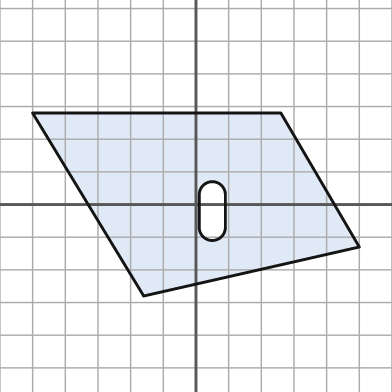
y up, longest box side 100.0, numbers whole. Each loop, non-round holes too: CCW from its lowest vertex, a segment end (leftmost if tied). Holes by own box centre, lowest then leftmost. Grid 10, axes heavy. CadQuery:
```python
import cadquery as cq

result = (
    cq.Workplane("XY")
    .moveTo(-16.0, -28.0)
    .lineTo(50.0, -13.0)
    .lineTo(26.0, 28.0)
    .lineTo(-50.0, 28.0)
    .close()
    .moveTo(1.0, -7.0)
    .threePointArc((5.0, -11.0), (9.0, -7.0))
    .lineTo(9.0, 3.0)
    .threePointArc((5.0, 7.0), (1.0, 3.0))
    .close()
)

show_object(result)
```